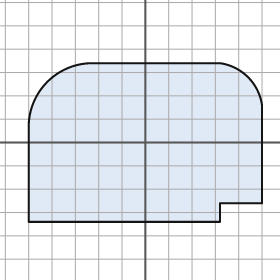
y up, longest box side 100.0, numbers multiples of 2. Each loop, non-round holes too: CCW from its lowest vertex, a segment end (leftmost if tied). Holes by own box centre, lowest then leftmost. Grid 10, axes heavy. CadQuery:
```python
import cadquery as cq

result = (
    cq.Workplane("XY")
    .moveTo(-50.0, -34.0)
    .lineTo(32.0, -34.0)
    .lineTo(32.0, -26.0)
    .lineTo(50.0, -26.0)
    .lineTo(50.0, 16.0)
    .threePointArc((44.0, 28.0), (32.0, 34.0))
    .lineTo(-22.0, 34.0)
    .threePointArc((-42.0, 26.0), (-50.0, 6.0))
    .close()
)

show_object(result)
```